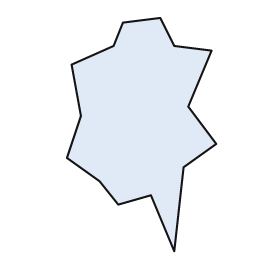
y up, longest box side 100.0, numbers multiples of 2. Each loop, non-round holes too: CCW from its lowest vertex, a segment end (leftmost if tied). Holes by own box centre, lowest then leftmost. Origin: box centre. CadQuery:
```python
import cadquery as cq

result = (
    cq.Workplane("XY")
    .moveTo(14.0, -50.0)
    .lineTo(18.0, -14.0)
    .lineTo(32.0, -4.0)
    .lineTo(20.0, 12.0)
    .lineTo(30.0, 36.0)
    .lineTo(14.0, 38.0)
    .lineTo(8.0, 50.0)
    .lineTo(-8.0, 48.0)
    .lineTo(-12.0, 38.0)
    .lineTo(-30.0, 30.0)
    .lineTo(-26.0, 8.0)
    .lineTo(-32.0, -10.0)
    .lineTo(-18.0, -20.0)
    .lineTo(-10.0, -30.0)
    .lineTo(4.0, -26.0)
    .close()
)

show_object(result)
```